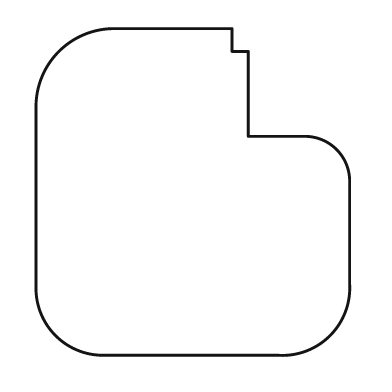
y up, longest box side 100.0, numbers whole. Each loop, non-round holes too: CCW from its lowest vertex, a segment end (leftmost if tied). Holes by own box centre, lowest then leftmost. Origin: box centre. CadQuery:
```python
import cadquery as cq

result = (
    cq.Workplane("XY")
    .moveTo(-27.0, -50.0)
    .lineTo(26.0, -50.0)
    .threePointArc((42.0, -44.0), (48.0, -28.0))
    .lineTo(48.0, 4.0)
    .threePointArc((44.0, 13.0), (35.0, 17.0))
    .lineTo(17.0, 17.0)
    .lineTo(17.0, 43.0)
    .lineTo(12.0, 43.0)
    .lineTo(12.0, 50.0)
    .lineTo(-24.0, 50.0)
    .threePointArc((-41.0, 43.0), (-48.0, 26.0))
    .lineTo(-48.0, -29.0)
    .threePointArc((-42.0, -44.0), (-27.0, -50.0))
    .close()
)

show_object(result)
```